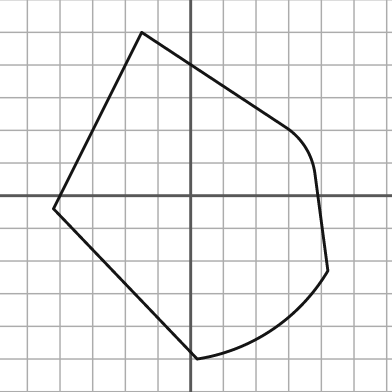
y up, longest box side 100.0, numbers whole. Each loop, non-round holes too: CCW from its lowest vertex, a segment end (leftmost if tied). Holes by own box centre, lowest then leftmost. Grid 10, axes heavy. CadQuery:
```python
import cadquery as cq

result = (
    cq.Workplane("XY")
    .moveTo(2.0, -50.0)
    .threePointArc((25.0, -41.0), (42.0, -23.0))
    .lineTo(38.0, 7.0)
    .threePointArc((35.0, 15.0), (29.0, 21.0))
    .lineTo(-15.0, 50.0)
    .lineTo(-42.0, -4.0)
    .close()
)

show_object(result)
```